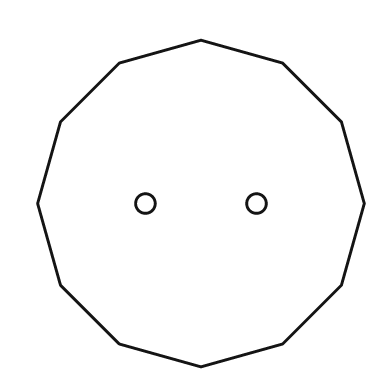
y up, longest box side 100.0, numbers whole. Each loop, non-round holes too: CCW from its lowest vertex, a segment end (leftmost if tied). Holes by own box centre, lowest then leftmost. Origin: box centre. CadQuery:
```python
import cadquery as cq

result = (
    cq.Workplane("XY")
    .moveTo(0.0, -50.0)
    .lineTo(25.0, -43.0)
    .lineTo(43.0, -25.0)
    .lineTo(50.0, 0.0)
    .lineTo(43.0, 25.0)
    .lineTo(25.0, 43.0)
    .lineTo(0.0, 50.0)
    .lineTo(-25.0, 43.0)
    .lineTo(-43.0, 25.0)
    .lineTo(-50.0, 0.0)
    .lineTo(-43.0, -25.0)
    .lineTo(-25.0, -43.0)
    .close()
    .moveTo(-17.0, 0.0)
    .circle(3.0)
    .moveTo(17.0, 0.0)
    .circle(3.0)
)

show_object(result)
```